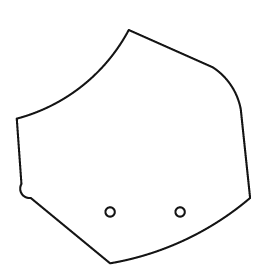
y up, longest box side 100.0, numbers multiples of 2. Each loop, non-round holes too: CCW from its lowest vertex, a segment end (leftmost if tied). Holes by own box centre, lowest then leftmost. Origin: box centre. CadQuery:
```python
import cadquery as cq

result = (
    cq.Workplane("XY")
    .moveTo(-10.0, -50.0)
    .threePointArc((22.0, -40.0), (50.0, -22.0))
    .lineTo(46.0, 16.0)
    .threePointArc((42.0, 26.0), (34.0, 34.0))
    .lineTo(-2.0, 50.0)
    .threePointArc((-22.0, 26.0), (-50.0, 12.0))
    .lineTo(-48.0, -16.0)
    .threePointArc((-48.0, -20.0), (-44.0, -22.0))
    .close()
    .moveTo(-10.0, -28.0)
    .circle(2.0)
    .moveTo(20.0, -28.0)
    .circle(2.0)
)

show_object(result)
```